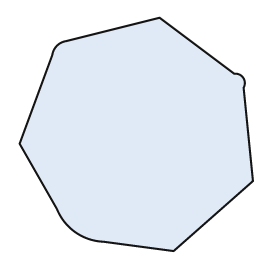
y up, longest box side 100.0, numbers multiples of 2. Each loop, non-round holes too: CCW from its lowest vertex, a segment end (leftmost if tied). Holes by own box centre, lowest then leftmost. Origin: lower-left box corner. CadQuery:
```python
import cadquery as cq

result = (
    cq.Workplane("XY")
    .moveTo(66.0, 0.0)
    .lineTo(100.0, 30.0)
    .lineTo(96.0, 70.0)
    .threePointArc((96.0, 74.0), (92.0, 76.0))
    .lineTo(60.0, 100.0)
    .lineTo(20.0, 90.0)
    .threePointArc((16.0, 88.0), (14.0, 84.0))
    .lineTo(0.0, 46.0)
    .lineTo(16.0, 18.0)
    .threePointArc((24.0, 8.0), (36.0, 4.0))
    .close()
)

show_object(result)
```